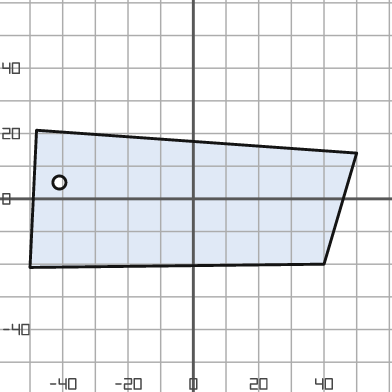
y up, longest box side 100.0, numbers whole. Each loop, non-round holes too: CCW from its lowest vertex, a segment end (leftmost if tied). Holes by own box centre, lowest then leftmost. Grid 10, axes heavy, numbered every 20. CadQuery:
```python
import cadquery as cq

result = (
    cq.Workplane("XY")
    .moveTo(-50.0, -21.0)
    .lineTo(40.0, -20.0)
    .lineTo(50.0, 14.0)
    .lineTo(-48.0, 21.0)
    .close()
    .moveTo(-41.0, 5.0)
    .circle(2.0)
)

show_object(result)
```